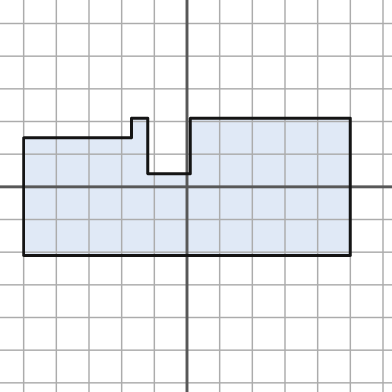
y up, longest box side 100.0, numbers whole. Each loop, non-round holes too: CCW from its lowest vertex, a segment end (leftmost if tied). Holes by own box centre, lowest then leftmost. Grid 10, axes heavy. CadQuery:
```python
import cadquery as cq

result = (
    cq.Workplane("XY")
    .moveTo(-50.0, -21.0)
    .lineTo(50.0, -21.0)
    .lineTo(50.0, 21.0)
    .lineTo(1.0, 21.0)
    .lineTo(1.0, 4.0)
    .lineTo(-12.0, 4.0)
    .lineTo(-12.0, 21.0)
    .lineTo(-17.0, 21.0)
    .lineTo(-17.0, 15.0)
    .lineTo(-50.0, 15.0)
    .close()
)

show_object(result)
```